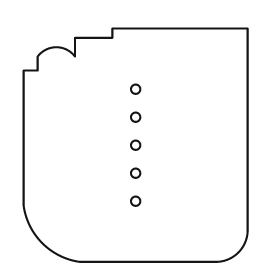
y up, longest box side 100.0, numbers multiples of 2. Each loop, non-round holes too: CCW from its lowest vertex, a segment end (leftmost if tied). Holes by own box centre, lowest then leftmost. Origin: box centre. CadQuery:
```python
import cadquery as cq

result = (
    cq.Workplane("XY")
    .moveTo(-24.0, -50.0)
    .lineTo(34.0, -50.0)
    .threePointArc((44.0, -46.0), (48.0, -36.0))
    .lineTo(48.0, 50.0)
    .lineTo(-10.0, 50.0)
    .lineTo(-10.0, 46.0)
    .lineTo(-26.0, 46.0)
    .lineTo(-26.0, 38.0)
    .threePointArc((-34.0, 42.0), (-42.0, 38.0))
    .lineTo(-42.0, 32.0)
    .lineTo(-48.0, 32.0)
    .lineTo(-48.0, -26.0)
    .threePointArc((-40.0, -42.0), (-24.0, -50.0))
    .close()
    .moveTo(0.0, -24.0)
    .circle(2.0)
    .moveTo(0.0, -12.0)
    .circle(2.0)
    .moveTo(0.0, 0.0)
    .circle(2.0)
    .moveTo(0.0, 12.0)
    .circle(2.0)
    .moveTo(0.0, 24.0)
    .circle(2.0)
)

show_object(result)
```